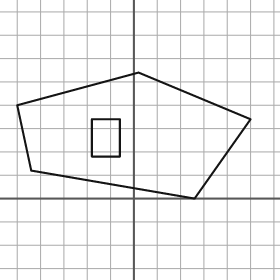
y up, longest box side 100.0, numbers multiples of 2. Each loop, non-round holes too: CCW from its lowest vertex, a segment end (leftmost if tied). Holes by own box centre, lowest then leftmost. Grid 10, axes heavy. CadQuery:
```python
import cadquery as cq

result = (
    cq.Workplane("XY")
    .moveTo(26.0, 0.0)
    .lineTo(50.0, 34.0)
    .lineTo(2.0, 54.0)
    .lineTo(-50.0, 40.0)
    .lineTo(-44.0, 12.0)
    .close()
    .moveTo(-18.0, 18.0)
    .lineTo(-6.0, 18.0)
    .lineTo(-6.0, 34.0)
    .lineTo(-18.0, 34.0)
    .close()
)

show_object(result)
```